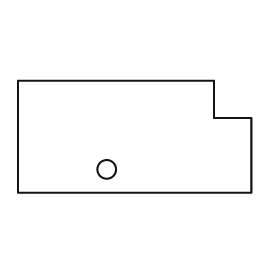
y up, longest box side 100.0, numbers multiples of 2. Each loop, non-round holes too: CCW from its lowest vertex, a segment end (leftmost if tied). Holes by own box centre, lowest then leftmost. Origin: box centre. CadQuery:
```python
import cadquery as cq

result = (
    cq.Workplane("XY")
    .moveTo(-50.0, -24.0)
    .lineTo(50.0, -24.0)
    .lineTo(50.0, 8.0)
    .lineTo(34.0, 8.0)
    .lineTo(34.0, 24.0)
    .lineTo(-50.0, 24.0)
    .close()
    .moveTo(-12.0, -14.0)
    .circle(4.0)
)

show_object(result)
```